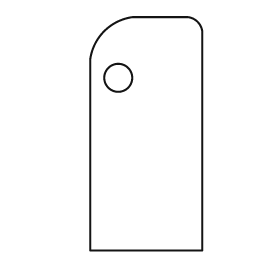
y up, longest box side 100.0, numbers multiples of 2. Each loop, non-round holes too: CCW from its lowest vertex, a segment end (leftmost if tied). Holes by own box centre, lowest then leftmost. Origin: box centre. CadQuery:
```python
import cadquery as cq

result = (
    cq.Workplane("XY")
    .moveTo(-24.0, -50.0)
    .lineTo(24.0, -50.0)
    .lineTo(24.0, 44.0)
    .threePointArc((22.0, 48.0), (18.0, 50.0))
    .lineTo(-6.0, 50.0)
    .threePointArc((-18.0, 44.0), (-24.0, 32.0))
    .close()
    .moveTo(-12.0, 24.0)
    .circle(6.0)
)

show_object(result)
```